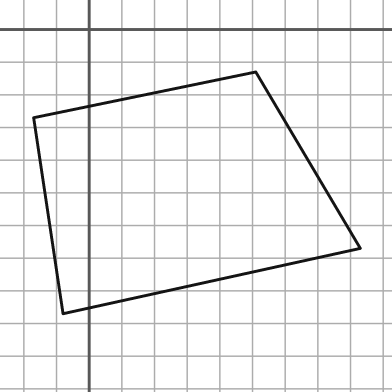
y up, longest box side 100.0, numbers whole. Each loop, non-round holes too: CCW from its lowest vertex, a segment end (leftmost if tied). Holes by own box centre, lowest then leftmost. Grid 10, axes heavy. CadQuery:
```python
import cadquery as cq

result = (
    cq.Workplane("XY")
    .moveTo(-8.0, -87.0)
    .lineTo(83.0, -67.0)
    .lineTo(51.0, -13.0)
    .lineTo(-17.0, -27.0)
    .close()
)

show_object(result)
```